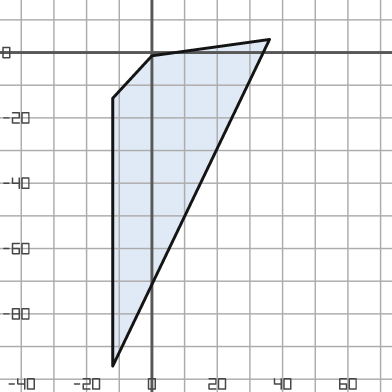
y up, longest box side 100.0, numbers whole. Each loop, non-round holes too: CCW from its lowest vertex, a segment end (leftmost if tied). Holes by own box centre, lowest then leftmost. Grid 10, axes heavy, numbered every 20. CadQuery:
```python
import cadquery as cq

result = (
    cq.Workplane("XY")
    .moveTo(-12.0, -96.0)
    .lineTo(36.0, 4.0)
    .lineTo(0.0, -1.0)
    .lineTo(-12.0, -14.0)
    .close()
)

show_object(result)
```